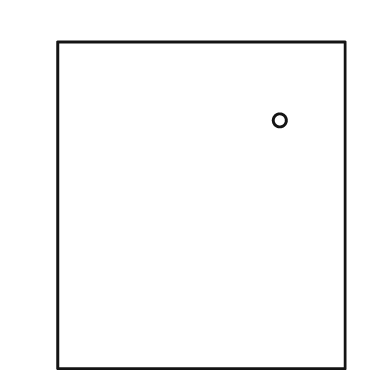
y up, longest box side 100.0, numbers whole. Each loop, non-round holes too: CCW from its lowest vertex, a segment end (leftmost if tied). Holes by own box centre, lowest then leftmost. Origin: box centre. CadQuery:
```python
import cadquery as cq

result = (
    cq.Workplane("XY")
    .moveTo(-44.0, -50.0)
    .lineTo(44.0, -50.0)
    .lineTo(44.0, 50.0)
    .lineTo(-44.0, 50.0)
    .close()
    .moveTo(24.0, 26.0)
    .circle(2.0)
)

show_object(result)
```